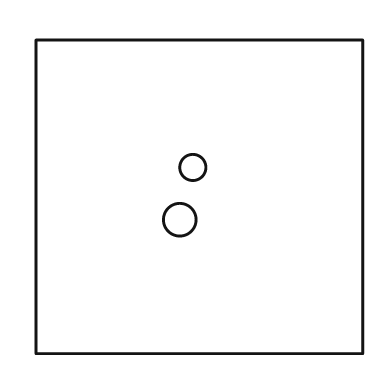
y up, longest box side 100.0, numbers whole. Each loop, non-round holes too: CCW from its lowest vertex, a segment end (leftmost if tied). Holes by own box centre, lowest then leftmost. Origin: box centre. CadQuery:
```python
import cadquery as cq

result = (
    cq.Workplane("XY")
    .moveTo(-50.0, -48.0)
    .lineTo(50.0, -48.0)
    .lineTo(50.0, 48.0)
    .lineTo(-50.0, 48.0)
    .close()
    .moveTo(-6.0, -7.0)
    .circle(5.0)
    .moveTo(-2.0, 9.0)
    .circle(4.0)
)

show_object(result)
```